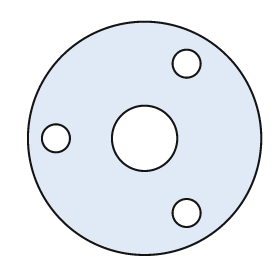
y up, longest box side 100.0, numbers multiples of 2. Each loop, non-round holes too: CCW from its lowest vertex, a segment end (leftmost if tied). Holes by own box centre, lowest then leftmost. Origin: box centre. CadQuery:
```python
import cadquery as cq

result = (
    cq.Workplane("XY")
    .moveTo(0.0, 0.0)
    .circle(50.0)
    .moveTo(18.0, -32.0)
    .circle(6.0)
    .moveTo(-38.0, 0.0)
    .circle(6.0)
    .moveTo(0.0, 0.0)
    .circle(14.0)
    .moveTo(18.0, 32.0)
    .circle(6.0)
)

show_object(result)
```